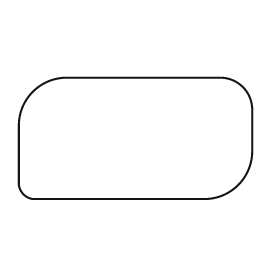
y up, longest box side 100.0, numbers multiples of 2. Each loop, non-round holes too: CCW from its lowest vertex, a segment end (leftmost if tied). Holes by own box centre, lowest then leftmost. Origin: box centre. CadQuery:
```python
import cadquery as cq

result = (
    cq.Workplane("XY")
    .moveTo(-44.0, -26.0)
    .lineTo(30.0, -26.0)
    .threePointArc((44.0, -20.0), (50.0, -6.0))
    .lineTo(50.0, 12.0)
    .threePointArc((46.0, 22.0), (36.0, 26.0))
    .lineTo(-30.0, 26.0)
    .threePointArc((-44.0, 20.0), (-50.0, 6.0))
    .lineTo(-50.0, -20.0)
    .threePointArc((-48.0, -24.0), (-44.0, -26.0))
    .close()
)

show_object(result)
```